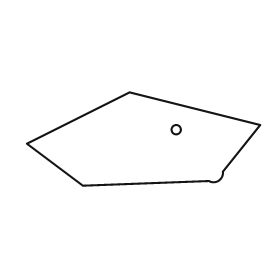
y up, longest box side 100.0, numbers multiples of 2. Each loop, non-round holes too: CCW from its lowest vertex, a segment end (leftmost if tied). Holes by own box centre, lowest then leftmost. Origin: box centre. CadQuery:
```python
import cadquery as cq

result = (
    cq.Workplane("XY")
    .moveTo(-26.0, -20.0)
    .lineTo(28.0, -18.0)
    .threePointArc((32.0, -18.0), (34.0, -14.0))
    .lineTo(50.0, 6.0)
    .lineTo(-6.0, 20.0)
    .lineTo(-50.0, -2.0)
    .close()
    .moveTo(14.0, 4.0)
    .circle(2.0)
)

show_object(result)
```